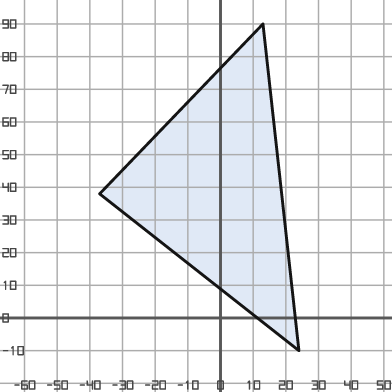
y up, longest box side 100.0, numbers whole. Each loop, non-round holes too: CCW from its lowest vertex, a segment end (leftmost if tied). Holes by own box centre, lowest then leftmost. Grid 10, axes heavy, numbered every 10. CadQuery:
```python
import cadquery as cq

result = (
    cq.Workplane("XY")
    .moveTo(24.0, -10.0)
    .lineTo(13.0, 90.0)
    .lineTo(-37.0, 38.0)
    .close()
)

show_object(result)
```